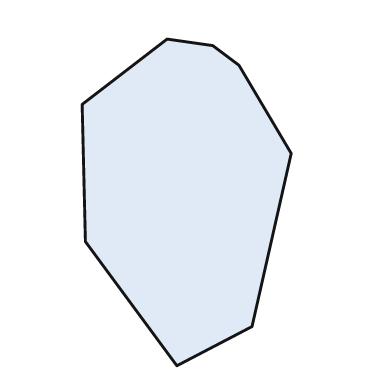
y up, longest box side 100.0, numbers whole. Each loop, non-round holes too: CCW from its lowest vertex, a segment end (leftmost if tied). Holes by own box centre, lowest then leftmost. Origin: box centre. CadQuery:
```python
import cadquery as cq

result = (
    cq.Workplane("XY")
    .moveTo(-3.0, -50.0)
    .lineTo(20.0, -38.0)
    .lineTo(32.0, 15.0)
    .lineTo(16.0, 42.0)
    .lineTo(8.0, 48.0)
    .lineTo(-6.0, 50.0)
    .lineTo(-32.0, 30.0)
    .lineTo(-31.0, -12.0)
    .close()
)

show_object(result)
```